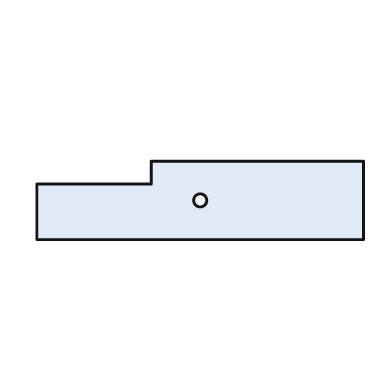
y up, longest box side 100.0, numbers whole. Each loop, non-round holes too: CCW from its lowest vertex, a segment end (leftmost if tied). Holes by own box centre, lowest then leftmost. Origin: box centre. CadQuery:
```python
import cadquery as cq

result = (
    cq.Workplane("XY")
    .moveTo(-50.0, -12.0)
    .lineTo(50.0, -12.0)
    .lineTo(50.0, 12.0)
    .lineTo(-15.0, 12.0)
    .lineTo(-15.0, 5.0)
    .lineTo(-50.0, 5.0)
    .close()
    .moveTo(0.0, 0.0)
    .circle(2.0)
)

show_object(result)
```